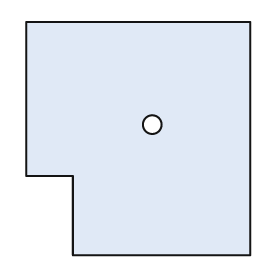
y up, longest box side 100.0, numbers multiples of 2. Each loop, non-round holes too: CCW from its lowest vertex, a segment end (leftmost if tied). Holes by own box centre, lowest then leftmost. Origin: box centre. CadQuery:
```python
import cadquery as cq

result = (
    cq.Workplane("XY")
    .moveTo(-28.0, -50.0)
    .lineTo(48.0, -50.0)
    .lineTo(48.0, 50.0)
    .lineTo(-48.0, 50.0)
    .lineTo(-48.0, -16.0)
    .lineTo(-28.0, -16.0)
    .close()
    .moveTo(6.0, 6.0)
    .circle(4.0)
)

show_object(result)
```